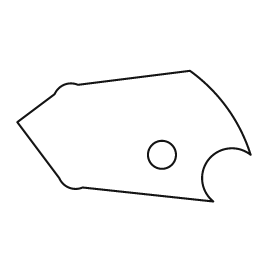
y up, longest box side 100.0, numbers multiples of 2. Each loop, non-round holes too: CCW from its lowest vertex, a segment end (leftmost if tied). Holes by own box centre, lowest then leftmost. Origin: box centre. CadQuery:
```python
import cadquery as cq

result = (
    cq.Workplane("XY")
    .moveTo(34.0, -28.0)
    .threePointArc((32.0, -10.0), (50.0, -8.0))
    .threePointArc((40.0, 12.0), (24.0, 28.0))
    .lineTo(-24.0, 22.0)
    .threePointArc((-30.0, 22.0), (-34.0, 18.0))
    .lineTo(-50.0, 6.0)
    .lineTo(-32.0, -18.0)
    .threePointArc((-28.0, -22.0), (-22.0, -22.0))
    .close()
    .moveTo(12.0, -8.0)
    .circle(6.0)
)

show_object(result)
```